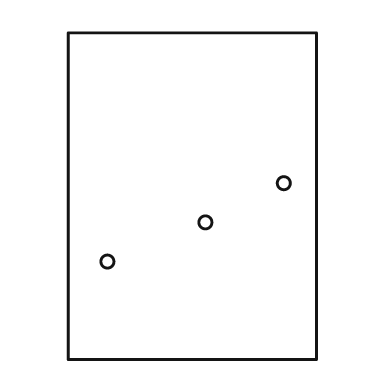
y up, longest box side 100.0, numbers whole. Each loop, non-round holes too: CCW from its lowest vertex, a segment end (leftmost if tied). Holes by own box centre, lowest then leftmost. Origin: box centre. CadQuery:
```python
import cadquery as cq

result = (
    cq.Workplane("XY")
    .moveTo(-38.0, -50.0)
    .lineTo(38.0, -50.0)
    .lineTo(38.0, 50.0)
    .lineTo(-38.0, 50.0)
    .close()
    .moveTo(-26.0, -20.0)
    .circle(2.0)
    .moveTo(4.0, -8.0)
    .circle(2.0)
    .moveTo(28.0, 4.0)
    .circle(2.0)
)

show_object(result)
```